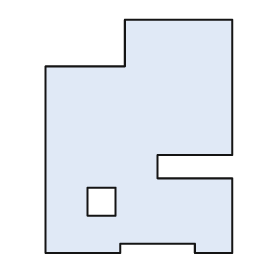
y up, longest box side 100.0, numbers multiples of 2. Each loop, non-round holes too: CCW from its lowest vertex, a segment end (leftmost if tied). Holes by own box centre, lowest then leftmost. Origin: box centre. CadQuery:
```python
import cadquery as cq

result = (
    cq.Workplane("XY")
    .moveTo(-40.0, -50.0)
    .lineTo(-8.0, -50.0)
    .lineTo(-8.0, -46.0)
    .lineTo(24.0, -46.0)
    .lineTo(24.0, -50.0)
    .lineTo(40.0, -50.0)
    .lineTo(40.0, -18.0)
    .lineTo(8.0, -18.0)
    .lineTo(8.0, -8.0)
    .lineTo(40.0, -8.0)
    .lineTo(40.0, 50.0)
    .lineTo(-6.0, 50.0)
    .lineTo(-6.0, 30.0)
    .lineTo(-40.0, 30.0)
    .close()
    .moveTo(-22.0, -34.0)
    .lineTo(-10.0, -34.0)
    .lineTo(-10.0, -22.0)
    .lineTo(-22.0, -22.0)
    .close()
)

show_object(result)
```